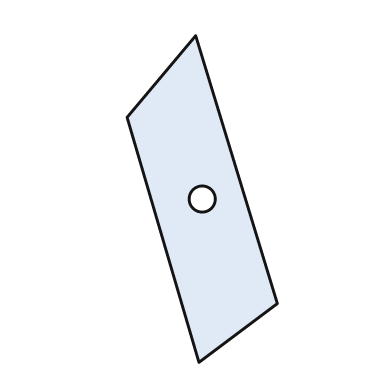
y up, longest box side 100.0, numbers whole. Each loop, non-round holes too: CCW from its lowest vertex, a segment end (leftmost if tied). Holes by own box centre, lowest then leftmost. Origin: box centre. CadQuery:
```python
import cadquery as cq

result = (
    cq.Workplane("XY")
    .moveTo(-1.0, -50.0)
    .lineTo(23.0, -32.0)
    .lineTo(-2.0, 50.0)
    .lineTo(-23.0, 25.0)
    .close()
    .moveTo(0.0, 0.0)
    .circle(4.0)
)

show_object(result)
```